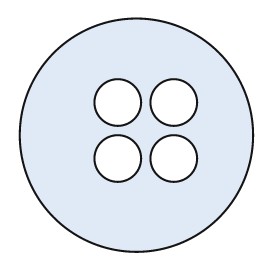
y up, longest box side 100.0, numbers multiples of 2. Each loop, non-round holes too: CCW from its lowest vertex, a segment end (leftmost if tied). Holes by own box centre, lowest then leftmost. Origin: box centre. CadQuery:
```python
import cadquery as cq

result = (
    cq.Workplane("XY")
    .moveTo(0.0, 0.0)
    .circle(50.0)
    .moveTo(-8.0, -10.0)
    .circle(10.0)
    .moveTo(16.0, -10.0)
    .circle(10.0)
    .moveTo(-8.0, 14.0)
    .circle(10.0)
    .moveTo(16.0, 14.0)
    .circle(10.0)
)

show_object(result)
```